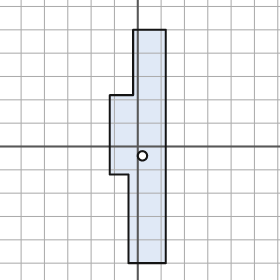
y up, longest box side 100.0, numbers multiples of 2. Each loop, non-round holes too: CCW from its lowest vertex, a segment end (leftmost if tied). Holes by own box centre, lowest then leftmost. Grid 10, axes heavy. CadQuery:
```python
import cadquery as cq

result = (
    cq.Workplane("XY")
    .moveTo(-4.0, -50.0)
    .lineTo(12.0, -50.0)
    .lineTo(12.0, 50.0)
    .lineTo(-2.0, 50.0)
    .lineTo(-2.0, 22.0)
    .lineTo(-12.0, 22.0)
    .lineTo(-12.0, -12.0)
    .lineTo(-4.0, -12.0)
    .close()
    .moveTo(2.0, -4.0)
    .circle(2.0)
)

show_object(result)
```